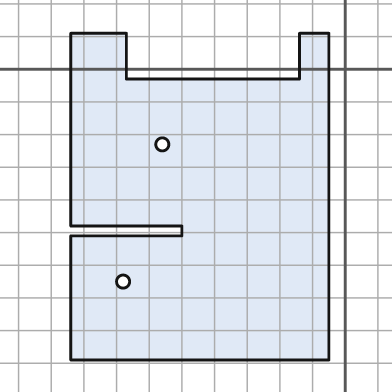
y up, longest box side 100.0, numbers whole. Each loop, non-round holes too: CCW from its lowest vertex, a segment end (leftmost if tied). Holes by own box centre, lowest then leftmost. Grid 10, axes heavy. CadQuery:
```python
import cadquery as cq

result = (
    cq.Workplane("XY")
    .moveTo(-84.0, -89.0)
    .lineTo(-5.0, -89.0)
    .lineTo(-5.0, 11.0)
    .lineTo(-14.0, 11.0)
    .lineTo(-14.0, -3.0)
    .lineTo(-67.0, -3.0)
    .lineTo(-67.0, 11.0)
    .lineTo(-84.0, 11.0)
    .lineTo(-84.0, -48.0)
    .lineTo(-50.0, -48.0)
    .lineTo(-50.0, -51.0)
    .lineTo(-84.0, -51.0)
    .close()
    .moveTo(-68.0, -65.0)
    .circle(2.0)
    .moveTo(-56.0, -23.0)
    .circle(2.0)
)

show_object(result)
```